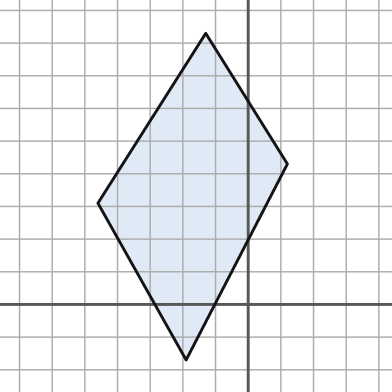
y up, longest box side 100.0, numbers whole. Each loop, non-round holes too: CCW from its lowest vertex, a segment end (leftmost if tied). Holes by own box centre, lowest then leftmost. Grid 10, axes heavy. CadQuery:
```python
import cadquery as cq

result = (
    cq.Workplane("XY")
    .moveTo(-19.0, -17.0)
    .lineTo(12.0, 43.0)
    .lineTo(-13.0, 83.0)
    .lineTo(-46.0, 31.0)
    .close()
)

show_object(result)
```